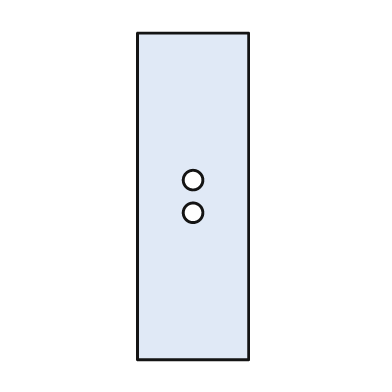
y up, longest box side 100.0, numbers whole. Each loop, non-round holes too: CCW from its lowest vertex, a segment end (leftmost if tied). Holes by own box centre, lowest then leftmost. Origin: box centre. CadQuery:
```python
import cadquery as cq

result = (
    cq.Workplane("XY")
    .moveTo(-17.0, -50.0)
    .lineTo(17.0, -50.0)
    .lineTo(17.0, 50.0)
    .lineTo(-17.0, 50.0)
    .close()
    .moveTo(0.0, -5.0)
    .circle(3.0)
    .moveTo(0.0, 5.0)
    .circle(3.0)
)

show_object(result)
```